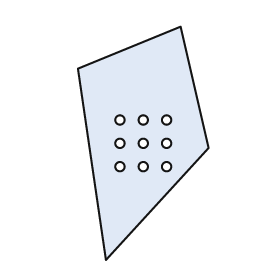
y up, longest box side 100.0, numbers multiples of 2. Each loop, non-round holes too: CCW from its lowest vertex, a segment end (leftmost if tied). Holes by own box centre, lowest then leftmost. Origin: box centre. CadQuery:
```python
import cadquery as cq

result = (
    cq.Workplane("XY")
    .moveTo(-16.0, -50.0)
    .lineTo(28.0, -2.0)
    .lineTo(16.0, 50.0)
    .lineTo(-28.0, 32.0)
    .close()
    .moveTo(-10.0, -10.0)
    .circle(2.0)
    .moveTo(0.0, -10.0)
    .circle(2.0)
    .moveTo(10.0, -10.0)
    .circle(2.0)
    .moveTo(-10.0, 0.0)
    .circle(2.0)
    .moveTo(0.0, 0.0)
    .circle(2.0)
    .moveTo(10.0, 0.0)
    .circle(2.0)
    .moveTo(-10.0, 10.0)
    .circle(2.0)
    .moveTo(0.0, 10.0)
    .circle(2.0)
    .moveTo(10.0, 10.0)
    .circle(2.0)
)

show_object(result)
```